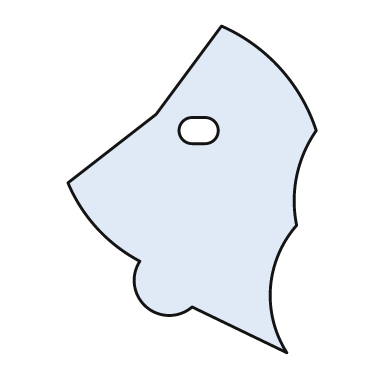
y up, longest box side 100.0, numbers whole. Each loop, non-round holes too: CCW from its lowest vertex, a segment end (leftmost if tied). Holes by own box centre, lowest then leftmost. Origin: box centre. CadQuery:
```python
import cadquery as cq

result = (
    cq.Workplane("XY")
    .moveTo(29.0, -50.0)
    .threePointArc((24.0, -30.0), (32.0, -11.0))
    .threePointArc((32.0, 4.0), (38.0, 18.0))
    .threePointArc((27.0, 37.0), (9.0, 50.0))
    .lineTo(-11.0, 23.0)
    .lineTo(-38.0, 2.0)
    .threePointArc((-29.0, -12.0), (-16.0, -22.0))
    .threePointArc((-14.0, -36.0), (0.0, -36.0))
    .close()
    .moveTo(0.0, 14.0)
    .lineTo(4.0, 14.0)
    .threePointArc((8.0, 18.0), (4.0, 22.0))
    .lineTo(0.0, 22.0)
    .threePointArc((-4.0, 18.0), (0.0, 14.0))
    .close()
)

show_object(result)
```